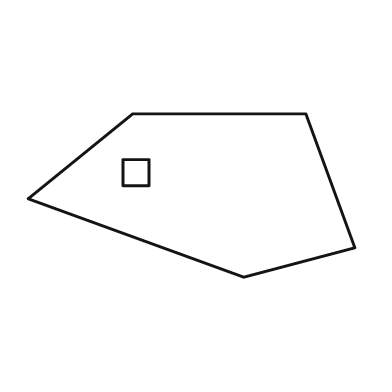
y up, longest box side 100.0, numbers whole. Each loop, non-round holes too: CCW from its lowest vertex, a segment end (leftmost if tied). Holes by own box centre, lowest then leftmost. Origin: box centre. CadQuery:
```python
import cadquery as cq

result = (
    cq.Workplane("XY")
    .moveTo(16.0, -25.0)
    .lineTo(50.0, -16.0)
    .lineTo(35.0, 25.0)
    .lineTo(-18.0, 25.0)
    .lineTo(-50.0, -1.0)
    .close()
    .moveTo(-21.0, 3.0)
    .lineTo(-13.0, 3.0)
    .lineTo(-13.0, 11.0)
    .lineTo(-21.0, 11.0)
    .close()
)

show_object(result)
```